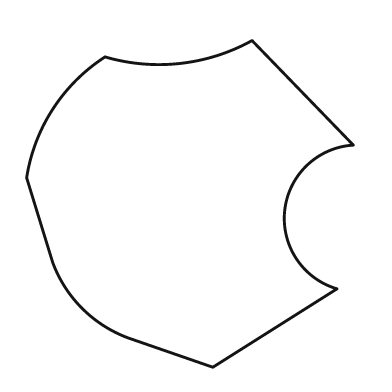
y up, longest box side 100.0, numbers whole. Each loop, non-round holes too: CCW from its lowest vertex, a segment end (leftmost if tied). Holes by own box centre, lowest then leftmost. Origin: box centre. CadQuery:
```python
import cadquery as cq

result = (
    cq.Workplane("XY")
    .moveTo(7.0, -50.0)
    .lineTo(45.0, -26.0)
    .threePointArc((29.0, -2.0), (50.0, 18.0))
    .lineTo(19.0, 50.0)
    .threePointArc((-3.0, 43.0), (-26.0, 45.0))
    .threePointArc((-42.0, 29.0), (-50.0, 8.0))
    .lineTo(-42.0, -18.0)
    .threePointArc((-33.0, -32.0), (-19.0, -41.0))
    .close()
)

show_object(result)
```